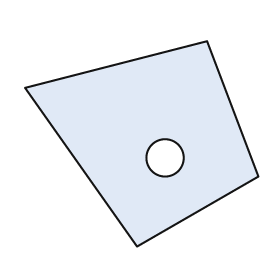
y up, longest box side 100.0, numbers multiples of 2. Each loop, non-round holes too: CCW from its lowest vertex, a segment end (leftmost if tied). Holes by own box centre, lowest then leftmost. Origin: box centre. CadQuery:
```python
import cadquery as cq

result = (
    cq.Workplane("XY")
    .moveTo(-2.0, -44.0)
    .lineTo(50.0, -14.0)
    .lineTo(28.0, 44.0)
    .lineTo(-50.0, 24.0)
    .close()
    .moveTo(10.0, -6.0)
    .circle(8.0)
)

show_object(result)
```